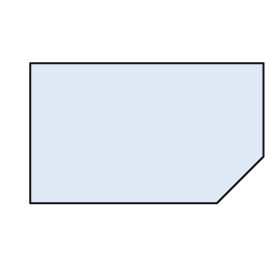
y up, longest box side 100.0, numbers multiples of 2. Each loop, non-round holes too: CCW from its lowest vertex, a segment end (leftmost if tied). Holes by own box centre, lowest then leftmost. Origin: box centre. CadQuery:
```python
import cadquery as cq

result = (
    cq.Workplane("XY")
    .moveTo(-50.0, -30.0)
    .lineTo(30.0, -30.0)
    .lineTo(50.0, -10.0)
    .lineTo(50.0, 30.0)
    .lineTo(-50.0, 30.0)
    .close()
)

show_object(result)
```